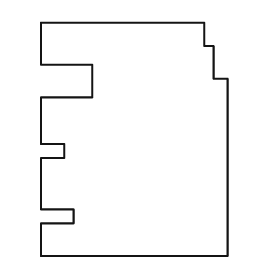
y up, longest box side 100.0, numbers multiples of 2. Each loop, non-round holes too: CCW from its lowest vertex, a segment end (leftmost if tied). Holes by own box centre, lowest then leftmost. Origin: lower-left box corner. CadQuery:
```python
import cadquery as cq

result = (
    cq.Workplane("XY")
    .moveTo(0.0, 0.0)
    .lineTo(80.0, 0.0)
    .lineTo(80.0, 76.0)
    .lineTo(74.0, 76.0)
    .lineTo(74.0, 90.0)
    .lineTo(70.0, 90.0)
    .lineTo(70.0, 100.0)
    .lineTo(0.0, 100.0)
    .lineTo(0.0, 82.0)
    .lineTo(22.0, 82.0)
    .lineTo(22.0, 68.0)
    .lineTo(0.0, 68.0)
    .lineTo(0.0, 48.0)
    .lineTo(10.0, 48.0)
    .lineTo(10.0, 42.0)
    .lineTo(0.0, 42.0)
    .lineTo(0.0, 20.0)
    .lineTo(14.0, 20.0)
    .lineTo(14.0, 14.0)
    .lineTo(0.0, 14.0)
    .close()
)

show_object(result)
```